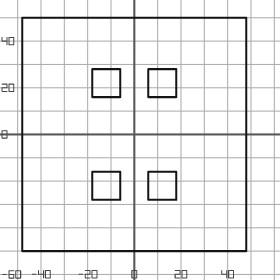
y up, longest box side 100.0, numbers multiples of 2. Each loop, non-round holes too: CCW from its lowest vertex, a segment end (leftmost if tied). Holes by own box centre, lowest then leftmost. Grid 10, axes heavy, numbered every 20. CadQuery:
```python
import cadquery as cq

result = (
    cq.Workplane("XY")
    .moveTo(-48.0, -50.0)
    .lineTo(48.0, -50.0)
    .lineTo(48.0, 50.0)
    .lineTo(-48.0, 50.0)
    .close()
    .moveTo(-18.0, -28.0)
    .lineTo(-6.0, -28.0)
    .lineTo(-6.0, -16.0)
    .lineTo(-18.0, -16.0)
    .close()
    .moveTo(6.0, -28.0)
    .lineTo(18.0, -28.0)
    .lineTo(18.0, -16.0)
    .lineTo(6.0, -16.0)
    .close()
    .moveTo(-18.0, 16.0)
    .lineTo(-6.0, 16.0)
    .lineTo(-6.0, 28.0)
    .lineTo(-18.0, 28.0)
    .close()
    .moveTo(6.0, 16.0)
    .lineTo(18.0, 16.0)
    .lineTo(18.0, 28.0)
    .lineTo(6.0, 28.0)
    .close()
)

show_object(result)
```